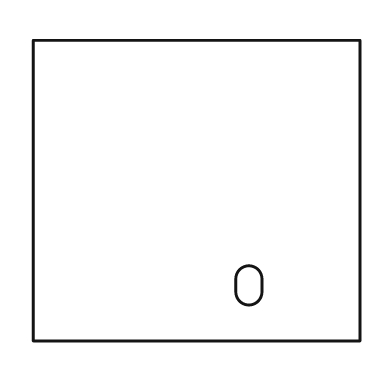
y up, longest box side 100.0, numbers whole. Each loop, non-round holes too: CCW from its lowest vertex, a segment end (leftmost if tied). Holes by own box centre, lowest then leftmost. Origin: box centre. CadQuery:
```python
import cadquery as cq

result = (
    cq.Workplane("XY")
    .moveTo(-50.0, -46.0)
    .lineTo(50.0, -46.0)
    .lineTo(50.0, 46.0)
    .lineTo(-50.0, 46.0)
    .close()
    .moveTo(12.0, -31.0)
    .threePointArc((16.0, -35.0), (20.0, -31.0))
    .lineTo(20.0, -27.0)
    .threePointArc((16.0, -23.0), (12.0, -27.0))
    .close()
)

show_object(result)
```